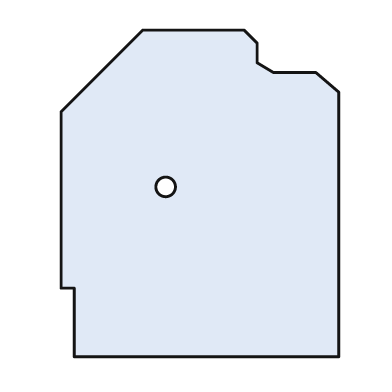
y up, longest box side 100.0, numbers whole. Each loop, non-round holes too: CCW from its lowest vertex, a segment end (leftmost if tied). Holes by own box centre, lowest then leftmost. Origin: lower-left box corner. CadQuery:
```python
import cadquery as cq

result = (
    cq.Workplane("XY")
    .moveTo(4.0, 0.0)
    .lineTo(85.0, 0.0)
    .lineTo(85.0, 81.0)
    .lineTo(78.0, 87.0)
    .lineTo(65.0, 87.0)
    .lineTo(60.0, 90.0)
    .lineTo(60.0, 96.0)
    .lineTo(56.0, 100.0)
    .lineTo(25.0, 100.0)
    .lineTo(0.0, 75.0)
    .lineTo(0.0, 21.0)
    .lineTo(4.0, 21.0)
    .close()
    .moveTo(32.0, 52.0)
    .circle(3.0)
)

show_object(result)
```